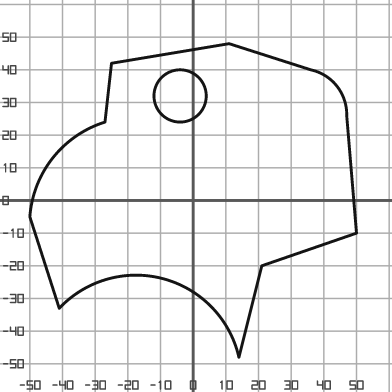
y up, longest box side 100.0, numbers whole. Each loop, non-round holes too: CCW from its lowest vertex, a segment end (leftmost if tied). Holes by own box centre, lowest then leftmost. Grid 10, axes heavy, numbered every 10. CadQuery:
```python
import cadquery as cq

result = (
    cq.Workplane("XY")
    .moveTo(14.0, -48.0)
    .lineTo(21.0, -20.0)
    .lineTo(50.0, -10.0)
    .lineTo(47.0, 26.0)
    .threePointArc((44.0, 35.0), (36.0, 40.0))
    .lineTo(11.0, 48.0)
    .lineTo(-25.0, 42.0)
    .lineTo(-27.0, 24.0)
    .threePointArc((-43.0, 13.0), (-50.0, -5.0))
    .lineTo(-41.0, -33.0)
    .threePointArc((-9.0, -24.0), (14.0, -48.0))
    .close()
    .moveTo(-4.0, 32.0)
    .circle(8.0)
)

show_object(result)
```